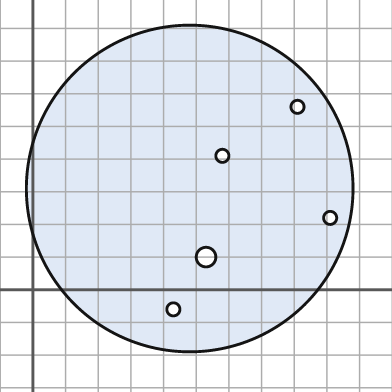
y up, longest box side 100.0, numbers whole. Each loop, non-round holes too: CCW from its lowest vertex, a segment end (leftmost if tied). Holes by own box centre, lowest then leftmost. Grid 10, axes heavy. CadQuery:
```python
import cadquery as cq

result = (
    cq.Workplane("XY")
    .moveTo(48.0, 31.0)
    .circle(50.0)
    .moveTo(43.0, -6.0)
    .circle(2.0)
    .moveTo(53.0, 10.0)
    .circle(3.0)
    .moveTo(91.0, 22.0)
    .circle(2.0)
    .moveTo(58.0, 41.0)
    .circle(2.0)
    .moveTo(81.0, 56.0)
    .circle(2.0)
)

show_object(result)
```